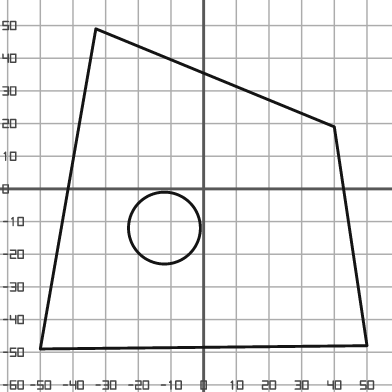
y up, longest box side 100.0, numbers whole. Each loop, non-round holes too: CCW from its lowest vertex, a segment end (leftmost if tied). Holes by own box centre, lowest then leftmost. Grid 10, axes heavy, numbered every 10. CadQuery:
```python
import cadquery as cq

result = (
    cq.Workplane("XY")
    .moveTo(-50.0, -49.0)
    .lineTo(50.0, -48.0)
    .lineTo(40.0, 19.0)
    .lineTo(-33.0, 49.0)
    .close()
    .moveTo(-12.0, -12.0)
    .circle(11.0)
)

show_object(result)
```